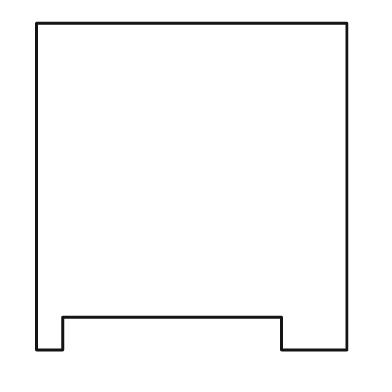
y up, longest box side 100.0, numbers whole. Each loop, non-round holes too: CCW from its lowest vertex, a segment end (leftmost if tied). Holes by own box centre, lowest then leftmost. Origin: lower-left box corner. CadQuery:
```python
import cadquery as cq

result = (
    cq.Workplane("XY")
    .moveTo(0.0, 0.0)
    .lineTo(8.0, 0.0)
    .lineTo(8.0, 10.0)
    .lineTo(75.0, 10.0)
    .lineTo(75.0, 0.0)
    .lineTo(95.0, 0.0)
    .lineTo(95.0, 100.0)
    .lineTo(0.0, 100.0)
    .close()
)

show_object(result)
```